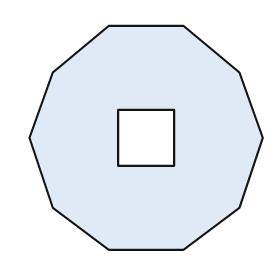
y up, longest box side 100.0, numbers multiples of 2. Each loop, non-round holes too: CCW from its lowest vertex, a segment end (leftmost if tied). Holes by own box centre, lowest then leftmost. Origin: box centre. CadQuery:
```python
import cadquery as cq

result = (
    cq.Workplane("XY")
    .moveTo(-16.0, -48.0)
    .lineTo(16.0, -48.0)
    .lineTo(40.0, -30.0)
    .lineTo(50.0, 0.0)
    .lineTo(40.0, 28.0)
    .lineTo(16.0, 48.0)
    .lineTo(-16.0, 48.0)
    .lineTo(-40.0, 28.0)
    .lineTo(-50.0, 0.0)
    .lineTo(-40.0, -30.0)
    .close()
    .moveTo(-12.0, -12.0)
    .lineTo(12.0, -12.0)
    .lineTo(12.0, 12.0)
    .lineTo(-12.0, 12.0)
    .close()
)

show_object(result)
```